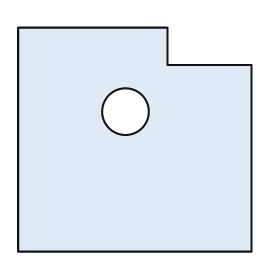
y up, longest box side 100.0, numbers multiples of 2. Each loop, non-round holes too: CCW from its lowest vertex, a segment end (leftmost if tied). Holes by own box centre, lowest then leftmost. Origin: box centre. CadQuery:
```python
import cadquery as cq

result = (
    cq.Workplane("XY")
    .moveTo(-50.0, -48.0)
    .lineTo(50.0, -48.0)
    .lineTo(50.0, 32.0)
    .lineTo(14.0, 32.0)
    .lineTo(14.0, 48.0)
    .lineTo(-50.0, 48.0)
    .close()
    .moveTo(-4.0, 12.0)
    .circle(10.0)
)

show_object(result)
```